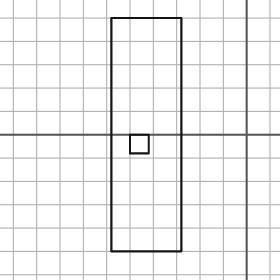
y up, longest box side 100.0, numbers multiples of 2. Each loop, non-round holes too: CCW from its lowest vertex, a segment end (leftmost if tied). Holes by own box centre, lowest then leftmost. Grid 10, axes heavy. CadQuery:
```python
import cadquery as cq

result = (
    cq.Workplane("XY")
    .moveTo(-58.0, -50.0)
    .lineTo(-28.0, -50.0)
    .lineTo(-28.0, 50.0)
    .lineTo(-58.0, 50.0)
    .close()
    .moveTo(-50.0, -8.0)
    .lineTo(-42.0, -8.0)
    .lineTo(-42.0, 0.0)
    .lineTo(-50.0, 0.0)
    .close()
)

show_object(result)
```